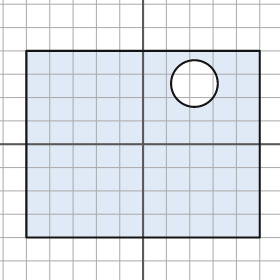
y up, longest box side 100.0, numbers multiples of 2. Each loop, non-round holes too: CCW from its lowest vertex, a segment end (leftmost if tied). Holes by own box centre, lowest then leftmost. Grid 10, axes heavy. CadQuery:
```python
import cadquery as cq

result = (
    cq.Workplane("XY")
    .moveTo(-50.0, -40.0)
    .lineTo(50.0, -40.0)
    .lineTo(50.0, 40.0)
    .lineTo(-50.0, 40.0)
    .close()
    .moveTo(22.0, 26.0)
    .circle(10.0)
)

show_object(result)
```